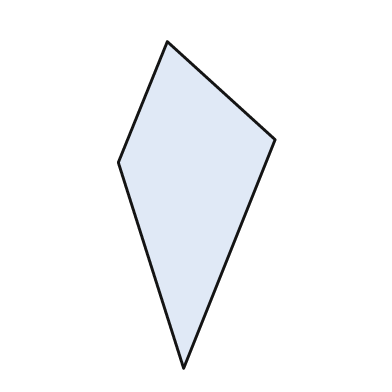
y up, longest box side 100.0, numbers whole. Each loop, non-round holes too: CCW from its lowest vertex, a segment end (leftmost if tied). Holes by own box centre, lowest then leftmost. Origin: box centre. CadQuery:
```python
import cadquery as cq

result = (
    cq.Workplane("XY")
    .moveTo(-4.0, -50.0)
    .lineTo(24.0, 20.0)
    .lineTo(-9.0, 50.0)
    .lineTo(-24.0, 13.0)
    .close()
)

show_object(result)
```